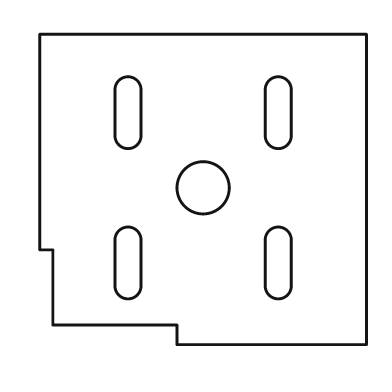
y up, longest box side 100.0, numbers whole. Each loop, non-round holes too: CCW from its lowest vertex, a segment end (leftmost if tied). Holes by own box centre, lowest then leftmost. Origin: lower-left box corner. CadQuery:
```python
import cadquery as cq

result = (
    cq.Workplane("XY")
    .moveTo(42.0, 0.0)
    .lineTo(100.0, 0.0)
    .lineTo(100.0, 95.0)
    .lineTo(0.0, 95.0)
    .lineTo(0.0, 29.0)
    .lineTo(4.0, 29.0)
    .lineTo(4.0, 6.0)
    .lineTo(42.0, 6.0)
    .close()
    .moveTo(23.0, 18.0)
    .threePointArc((27.0, 14.0), (31.0, 18.0))
    .lineTo(31.0, 32.0)
    .threePointArc((27.0, 36.0), (23.0, 32.0))
    .close()
    .moveTo(69.0, 18.0)
    .threePointArc((73.0, 14.0), (77.0, 18.0))
    .lineTo(77.0, 32.0)
    .threePointArc((73.0, 36.0), (69.0, 32.0))
    .close()
    .moveTo(50.0, 48.0)
    .circle(8.0)
    .moveTo(23.0, 64.0)
    .threePointArc((27.0, 60.0), (31.0, 64.0))
    .lineTo(31.0, 78.0)
    .threePointArc((27.0, 82.0), (23.0, 78.0))
    .close()
    .moveTo(69.0, 64.0)
    .threePointArc((73.0, 60.0), (77.0, 64.0))
    .lineTo(77.0, 78.0)
    .threePointArc((73.0, 82.0), (69.0, 78.0))
    .close()
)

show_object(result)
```